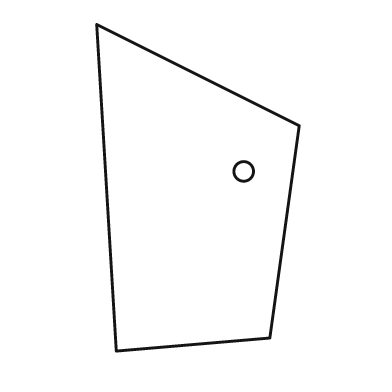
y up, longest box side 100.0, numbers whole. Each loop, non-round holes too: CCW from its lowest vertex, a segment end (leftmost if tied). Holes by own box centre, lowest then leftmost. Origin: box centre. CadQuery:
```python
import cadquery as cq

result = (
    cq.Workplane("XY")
    .moveTo(-25.0, -50.0)
    .lineTo(22.0, -46.0)
    .lineTo(31.0, 19.0)
    .lineTo(-31.0, 50.0)
    .close()
    .moveTo(14.0, 5.0)
    .circle(3.0)
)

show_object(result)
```